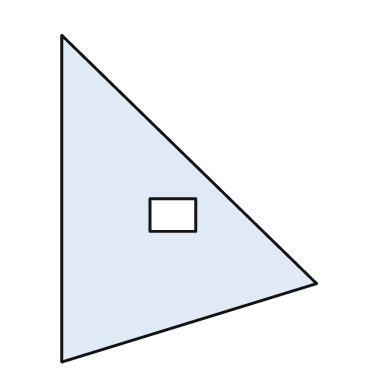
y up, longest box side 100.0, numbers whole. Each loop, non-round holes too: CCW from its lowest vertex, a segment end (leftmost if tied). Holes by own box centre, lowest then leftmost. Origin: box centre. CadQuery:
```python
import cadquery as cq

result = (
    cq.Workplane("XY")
    .moveTo(-39.0, -50.0)
    .lineTo(39.0, -26.0)
    .lineTo(-39.0, 50.0)
    .close()
    .moveTo(-12.0, -10.0)
    .lineTo(2.0, -10.0)
    .lineTo(2.0, 0.0)
    .lineTo(-12.0, 0.0)
    .close()
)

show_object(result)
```